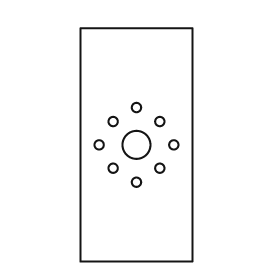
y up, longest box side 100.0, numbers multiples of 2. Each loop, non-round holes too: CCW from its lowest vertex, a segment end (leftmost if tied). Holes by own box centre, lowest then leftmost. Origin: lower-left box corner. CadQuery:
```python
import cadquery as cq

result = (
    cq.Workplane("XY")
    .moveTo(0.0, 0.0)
    .lineTo(48.0, 0.0)
    .lineTo(48.0, 100.0)
    .lineTo(0.0, 100.0)
    .close()
    .moveTo(24.0, 34.0)
    .circle(2.0)
    .moveTo(14.0, 40.0)
    .circle(2.0)
    .moveTo(34.0, 40.0)
    .circle(2.0)
    .moveTo(8.0, 50.0)
    .circle(2.0)
    .moveTo(24.0, 50.0)
    .circle(6.0)
    .moveTo(40.0, 50.0)
    .circle(2.0)
    .moveTo(14.0, 60.0)
    .circle(2.0)
    .moveTo(34.0, 60.0)
    .circle(2.0)
    .moveTo(24.0, 66.0)
    .circle(2.0)
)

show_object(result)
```